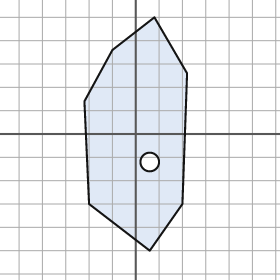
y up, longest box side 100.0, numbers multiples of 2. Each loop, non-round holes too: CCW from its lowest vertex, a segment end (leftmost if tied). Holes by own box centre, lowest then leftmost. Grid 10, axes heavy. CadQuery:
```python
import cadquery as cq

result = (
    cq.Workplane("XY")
    .moveTo(6.0, -50.0)
    .lineTo(20.0, -30.0)
    .lineTo(22.0, 26.0)
    .lineTo(8.0, 50.0)
    .lineTo(-10.0, 36.0)
    .lineTo(-22.0, 14.0)
    .lineTo(-20.0, -30.0)
    .close()
    .moveTo(6.0, -12.0)
    .circle(4.0)
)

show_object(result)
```